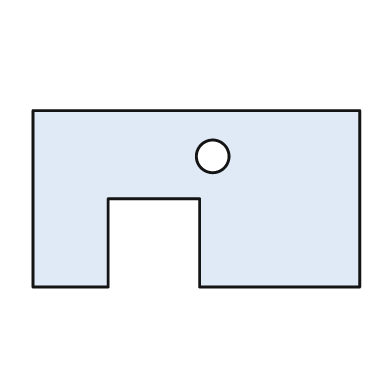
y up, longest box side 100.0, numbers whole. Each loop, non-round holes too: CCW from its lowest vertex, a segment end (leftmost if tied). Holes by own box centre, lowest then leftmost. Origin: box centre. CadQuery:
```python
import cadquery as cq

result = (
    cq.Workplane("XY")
    .moveTo(-50.0, -27.0)
    .lineTo(-27.0, -27.0)
    .lineTo(-27.0, 0.0)
    .lineTo(1.0, 0.0)
    .lineTo(1.0, -27.0)
    .lineTo(50.0, -27.0)
    .lineTo(50.0, 27.0)
    .lineTo(-50.0, 27.0)
    .close()
    .moveTo(5.0, 13.0)
    .circle(5.0)
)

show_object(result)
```